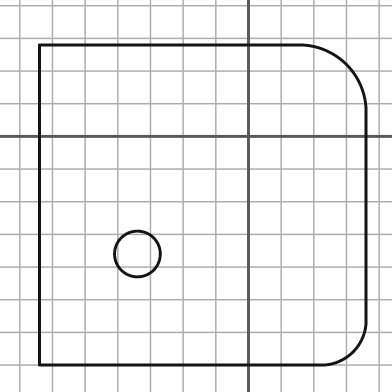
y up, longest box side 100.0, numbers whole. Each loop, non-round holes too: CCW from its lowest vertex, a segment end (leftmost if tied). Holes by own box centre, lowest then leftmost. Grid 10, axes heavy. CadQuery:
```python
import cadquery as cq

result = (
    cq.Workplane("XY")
    .moveTo(-64.0, -70.0)
    .lineTo(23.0, -70.0)
    .threePointArc((32.0, -66.0), (36.0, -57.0))
    .lineTo(36.0, 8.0)
    .threePointArc((30.0, 22.0), (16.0, 28.0))
    .lineTo(-64.0, 28.0)
    .close()
    .moveTo(-34.0, -36.0)
    .circle(7.0)
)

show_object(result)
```